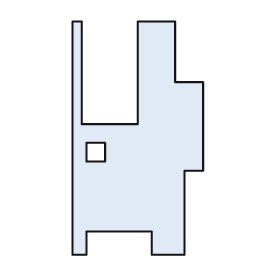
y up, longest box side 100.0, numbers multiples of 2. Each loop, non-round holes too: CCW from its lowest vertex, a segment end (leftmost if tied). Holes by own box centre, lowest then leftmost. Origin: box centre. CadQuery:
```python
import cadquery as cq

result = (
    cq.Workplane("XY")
    .moveTo(-28.0, -50.0)
    .lineTo(-22.0, -50.0)
    .lineTo(-22.0, -40.0)
    .lineTo(6.0, -40.0)
    .lineTo(6.0, -50.0)
    .lineTo(20.0, -50.0)
    .lineTo(20.0, -14.0)
    .lineTo(28.0, -14.0)
    .lineTo(28.0, 24.0)
    .lineTo(16.0, 24.0)
    .lineTo(16.0, 50.0)
    .lineTo(0.0, 50.0)
    .lineTo(0.0, 6.0)
    .lineTo(-24.0, 6.0)
    .lineTo(-24.0, 50.0)
    .lineTo(-28.0, 50.0)
    .close()
    .moveTo(-22.0, -10.0)
    .lineTo(-14.0, -10.0)
    .lineTo(-14.0, -2.0)
    .lineTo(-22.0, -2.0)
    .close()
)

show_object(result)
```